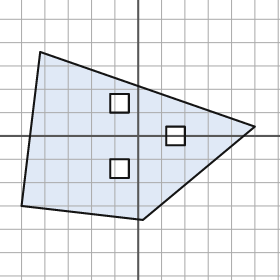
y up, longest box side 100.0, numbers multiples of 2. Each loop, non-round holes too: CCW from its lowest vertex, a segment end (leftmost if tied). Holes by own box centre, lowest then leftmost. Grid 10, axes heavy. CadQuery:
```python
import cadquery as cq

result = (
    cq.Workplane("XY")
    .moveTo(2.0, -36.0)
    .lineTo(50.0, 4.0)
    .lineTo(-42.0, 36.0)
    .lineTo(-50.0, -30.0)
    .close()
    .moveTo(-12.0, -18.0)
    .lineTo(-4.0, -18.0)
    .lineTo(-4.0, -10.0)
    .lineTo(-12.0, -10.0)
    .close()
    .moveTo(12.0, -4.0)
    .lineTo(20.0, -4.0)
    .lineTo(20.0, 4.0)
    .lineTo(12.0, 4.0)
    .close()
    .moveTo(-12.0, 10.0)
    .lineTo(-4.0, 10.0)
    .lineTo(-4.0, 18.0)
    .lineTo(-12.0, 18.0)
    .close()
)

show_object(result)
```